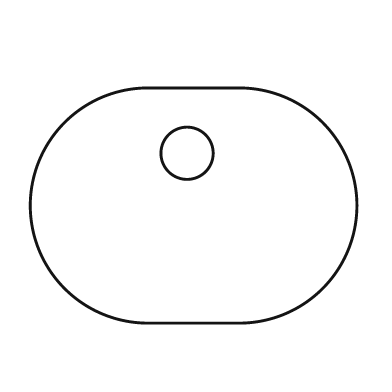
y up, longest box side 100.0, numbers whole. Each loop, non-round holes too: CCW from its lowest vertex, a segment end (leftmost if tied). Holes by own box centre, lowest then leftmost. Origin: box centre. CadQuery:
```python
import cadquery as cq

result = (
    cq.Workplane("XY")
    .moveTo(-14.0, -36.0)
    .lineTo(14.0, -36.0)
    .threePointArc((50.0, 0.0), (14.0, 36.0))
    .lineTo(-14.0, 36.0)
    .threePointArc((-50.0, 0.0), (-14.0, -36.0))
    .close()
    .moveTo(-2.0, 16.0)
    .circle(8.0)
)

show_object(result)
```